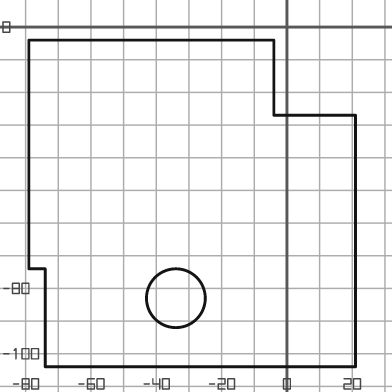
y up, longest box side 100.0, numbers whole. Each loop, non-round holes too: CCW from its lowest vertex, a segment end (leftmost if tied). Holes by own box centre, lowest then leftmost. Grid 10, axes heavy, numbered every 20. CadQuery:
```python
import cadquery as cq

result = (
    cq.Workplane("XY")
    .moveTo(-74.0, -104.0)
    .lineTo(21.0, -104.0)
    .lineTo(21.0, -27.0)
    .lineTo(-4.0, -27.0)
    .lineTo(-4.0, -4.0)
    .lineTo(-79.0, -4.0)
    .lineTo(-79.0, -74.0)
    .lineTo(-74.0, -74.0)
    .close()
    .moveTo(-34.0, -83.0)
    .circle(9.0)
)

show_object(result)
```